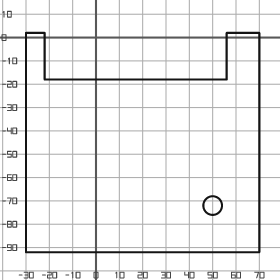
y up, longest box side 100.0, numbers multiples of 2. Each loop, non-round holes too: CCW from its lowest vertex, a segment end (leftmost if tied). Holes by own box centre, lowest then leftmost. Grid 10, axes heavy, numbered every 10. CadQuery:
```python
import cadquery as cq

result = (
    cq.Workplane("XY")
    .moveTo(-30.0, -92.0)
    .lineTo(70.0, -92.0)
    .lineTo(70.0, 2.0)
    .lineTo(56.0, 2.0)
    .lineTo(56.0, -18.0)
    .lineTo(-22.0, -18.0)
    .lineTo(-22.0, 2.0)
    .lineTo(-30.0, 2.0)
    .close()
    .moveTo(50.0, -72.0)
    .circle(4.0)
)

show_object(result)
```